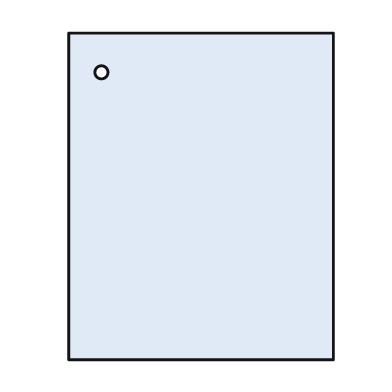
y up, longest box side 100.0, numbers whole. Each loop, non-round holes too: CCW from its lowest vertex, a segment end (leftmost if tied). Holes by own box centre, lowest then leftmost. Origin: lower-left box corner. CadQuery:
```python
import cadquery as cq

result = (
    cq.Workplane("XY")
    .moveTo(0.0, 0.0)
    .lineTo(81.0, 0.0)
    .lineTo(81.0, 100.0)
    .lineTo(0.0, 100.0)
    .close()
    .moveTo(10.0, 88.0)
    .circle(2.0)
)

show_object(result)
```